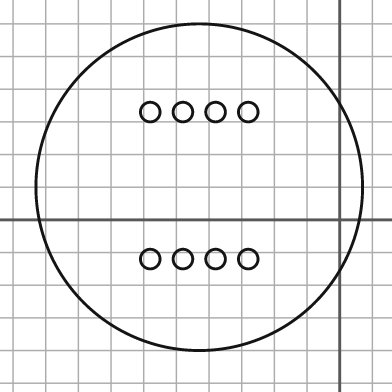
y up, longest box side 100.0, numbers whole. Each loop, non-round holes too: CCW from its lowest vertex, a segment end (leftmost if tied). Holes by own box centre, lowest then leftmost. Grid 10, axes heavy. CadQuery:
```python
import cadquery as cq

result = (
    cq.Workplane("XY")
    .moveTo(-43.0, 10.0)
    .circle(50.0)
    .moveTo(-58.0, -12.0)
    .circle(3.0)
    .moveTo(-48.0, -12.0)
    .circle(3.0)
    .moveTo(-38.0, -12.0)
    .circle(3.0)
    .moveTo(-28.0, -12.0)
    .circle(3.0)
    .moveTo(-58.0, 33.0)
    .circle(3.0)
    .moveTo(-48.0, 33.0)
    .circle(3.0)
    .moveTo(-38.0, 33.0)
    .circle(3.0)
    .moveTo(-28.0, 33.0)
    .circle(3.0)
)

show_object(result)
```